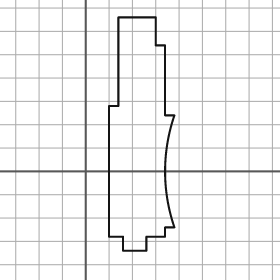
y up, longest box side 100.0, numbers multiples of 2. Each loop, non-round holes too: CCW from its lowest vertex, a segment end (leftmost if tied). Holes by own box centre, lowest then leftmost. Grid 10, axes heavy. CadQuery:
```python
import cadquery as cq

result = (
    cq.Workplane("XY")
    .moveTo(16.0, -34.0)
    .lineTo(26.0, -34.0)
    .lineTo(26.0, -28.0)
    .lineTo(34.0, -28.0)
    .lineTo(34.0, -24.0)
    .lineTo(38.0, -24.0)
    .threePointArc((34.0, 0.0), (38.0, 24.0))
    .lineTo(34.0, 24.0)
    .lineTo(34.0, 54.0)
    .lineTo(30.0, 54.0)
    .lineTo(30.0, 66.0)
    .lineTo(14.0, 66.0)
    .lineTo(14.0, 28.0)
    .lineTo(10.0, 28.0)
    .lineTo(10.0, -28.0)
    .lineTo(16.0, -28.0)
    .close()
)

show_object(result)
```